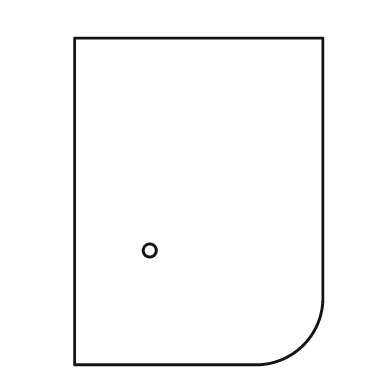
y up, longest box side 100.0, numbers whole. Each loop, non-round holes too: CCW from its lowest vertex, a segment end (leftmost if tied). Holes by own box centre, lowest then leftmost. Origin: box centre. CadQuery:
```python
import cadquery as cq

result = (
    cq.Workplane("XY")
    .moveTo(-38.0, -50.0)
    .lineTo(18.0, -50.0)
    .threePointArc((32.0, -44.0), (38.0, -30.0))
    .lineTo(38.0, 50.0)
    .lineTo(-38.0, 50.0)
    .close()
    .moveTo(-15.0, -15.0)
    .circle(2.0)
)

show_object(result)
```